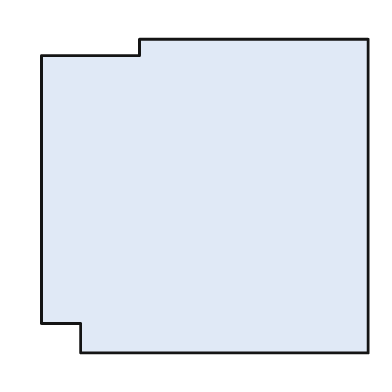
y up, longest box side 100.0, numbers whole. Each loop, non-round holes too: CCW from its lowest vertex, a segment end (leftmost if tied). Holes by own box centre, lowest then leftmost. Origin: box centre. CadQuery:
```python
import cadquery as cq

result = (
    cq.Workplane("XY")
    .moveTo(-38.0, -48.0)
    .lineTo(50.0, -48.0)
    .lineTo(50.0, 48.0)
    .lineTo(-20.0, 48.0)
    .lineTo(-20.0, 43.0)
    .lineTo(-50.0, 43.0)
    .lineTo(-50.0, -39.0)
    .lineTo(-38.0, -39.0)
    .close()
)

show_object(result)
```